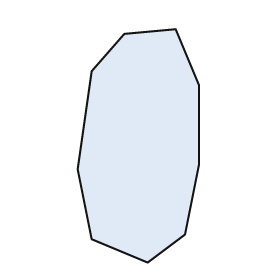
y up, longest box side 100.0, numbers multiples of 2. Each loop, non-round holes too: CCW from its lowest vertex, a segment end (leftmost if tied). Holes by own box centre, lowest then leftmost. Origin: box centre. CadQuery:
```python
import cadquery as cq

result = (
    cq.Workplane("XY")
    .moveTo(4.0, -50.0)
    .lineTo(20.0, -38.0)
    .lineTo(26.0, -8.0)
    .lineTo(26.0, 26.0)
    .lineTo(16.0, 50.0)
    .lineTo(-6.0, 48.0)
    .lineTo(-20.0, 32.0)
    .lineTo(-26.0, -10.0)
    .lineTo(-20.0, -40.0)
    .close()
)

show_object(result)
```